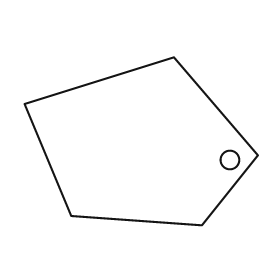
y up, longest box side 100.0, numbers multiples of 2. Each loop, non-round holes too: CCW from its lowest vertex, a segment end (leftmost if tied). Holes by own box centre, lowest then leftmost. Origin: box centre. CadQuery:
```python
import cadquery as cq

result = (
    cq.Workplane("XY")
    .moveTo(26.0, -36.0)
    .lineTo(50.0, -6.0)
    .lineTo(14.0, 36.0)
    .lineTo(-50.0, 16.0)
    .lineTo(-30.0, -32.0)
    .close()
    .moveTo(38.0, -8.0)
    .circle(4.0)
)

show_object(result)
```